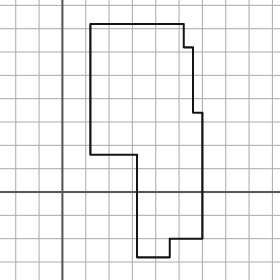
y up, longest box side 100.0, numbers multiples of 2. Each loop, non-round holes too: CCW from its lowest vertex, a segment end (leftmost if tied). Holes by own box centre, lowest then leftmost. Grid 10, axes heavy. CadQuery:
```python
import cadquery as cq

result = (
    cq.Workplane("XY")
    .moveTo(32.0, -28.0)
    .lineTo(46.0, -28.0)
    .lineTo(46.0, -20.0)
    .lineTo(60.0, -20.0)
    .lineTo(60.0, 34.0)
    .lineTo(56.0, 34.0)
    .lineTo(56.0, 62.0)
    .lineTo(52.0, 62.0)
    .lineTo(52.0, 72.0)
    .lineTo(12.0, 72.0)
    .lineTo(12.0, 16.0)
    .lineTo(32.0, 16.0)
    .close()
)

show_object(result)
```